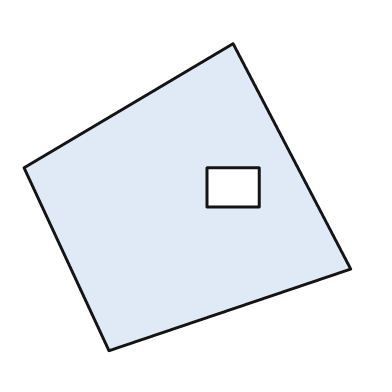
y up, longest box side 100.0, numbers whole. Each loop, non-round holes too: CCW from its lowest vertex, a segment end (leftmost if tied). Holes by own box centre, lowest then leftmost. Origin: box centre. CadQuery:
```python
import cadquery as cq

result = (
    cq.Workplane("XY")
    .moveTo(-24.0, -47.0)
    .lineTo(50.0, -22.0)
    .lineTo(14.0, 47.0)
    .lineTo(-50.0, 9.0)
    .close()
    .moveTo(6.0, -3.0)
    .lineTo(22.0, -3.0)
    .lineTo(22.0, 9.0)
    .lineTo(6.0, 9.0)
    .close()
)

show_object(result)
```